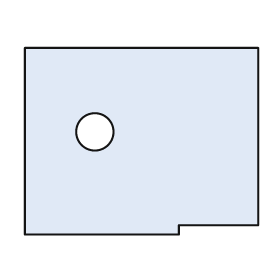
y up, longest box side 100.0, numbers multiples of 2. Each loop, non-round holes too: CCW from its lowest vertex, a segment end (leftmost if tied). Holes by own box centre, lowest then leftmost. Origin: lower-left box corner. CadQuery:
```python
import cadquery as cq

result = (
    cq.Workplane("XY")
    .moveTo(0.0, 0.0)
    .lineTo(66.0, 0.0)
    .lineTo(66.0, 4.0)
    .lineTo(100.0, 4.0)
    .lineTo(100.0, 80.0)
    .lineTo(0.0, 80.0)
    .close()
    .moveTo(30.0, 44.0)
    .circle(8.0)
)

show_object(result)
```